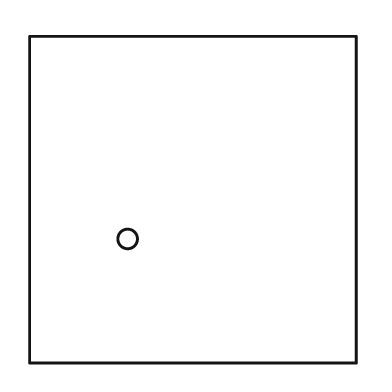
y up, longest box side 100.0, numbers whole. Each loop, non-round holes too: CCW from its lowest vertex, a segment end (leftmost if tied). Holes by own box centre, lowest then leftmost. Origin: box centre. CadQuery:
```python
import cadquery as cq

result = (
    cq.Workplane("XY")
    .moveTo(-50.0, -50.0)
    .lineTo(50.0, -50.0)
    .lineTo(50.0, 50.0)
    .lineTo(-50.0, 50.0)
    .close()
    .moveTo(-20.0, -12.0)
    .circle(3.0)
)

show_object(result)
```